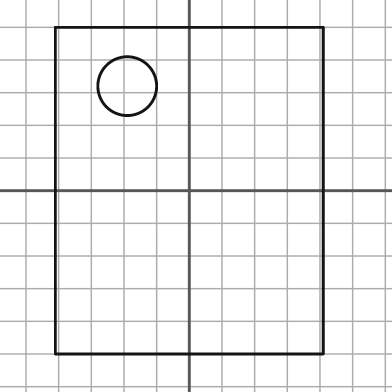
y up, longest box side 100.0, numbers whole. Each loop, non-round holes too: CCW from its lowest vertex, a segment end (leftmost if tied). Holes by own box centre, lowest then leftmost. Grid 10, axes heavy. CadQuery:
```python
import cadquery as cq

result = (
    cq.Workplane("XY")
    .moveTo(-41.0, -50.0)
    .lineTo(41.0, -50.0)
    .lineTo(41.0, 50.0)
    .lineTo(-41.0, 50.0)
    .close()
    .moveTo(-19.0, 32.0)
    .circle(9.0)
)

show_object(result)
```